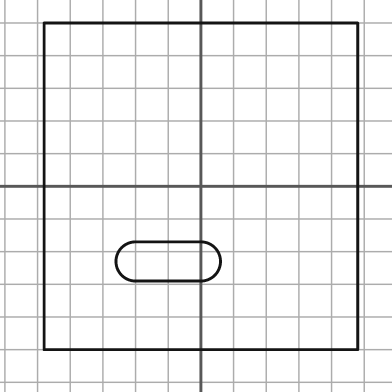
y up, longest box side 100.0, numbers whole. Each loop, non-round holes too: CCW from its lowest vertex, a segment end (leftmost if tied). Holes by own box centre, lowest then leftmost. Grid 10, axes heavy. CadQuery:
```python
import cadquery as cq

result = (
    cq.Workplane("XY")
    .moveTo(-48.0, -50.0)
    .lineTo(48.0, -50.0)
    .lineTo(48.0, 50.0)
    .lineTo(-48.0, 50.0)
    .close()
    .moveTo(-20.0, -29.0)
    .lineTo(0.0, -29.0)
    .threePointArc((6.0, -23.0), (0.0, -17.0))
    .lineTo(-20.0, -17.0)
    .threePointArc((-26.0, -23.0), (-20.0, -29.0))
    .close()
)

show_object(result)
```